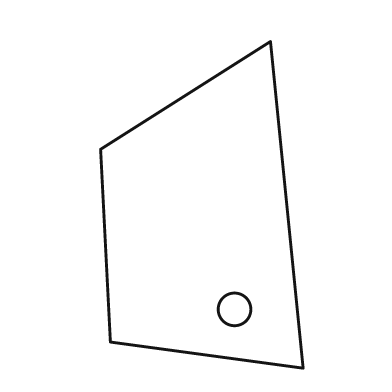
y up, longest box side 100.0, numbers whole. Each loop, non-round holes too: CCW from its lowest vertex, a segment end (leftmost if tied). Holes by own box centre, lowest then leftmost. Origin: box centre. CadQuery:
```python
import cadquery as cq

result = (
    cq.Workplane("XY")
    .moveTo(31.0, -50.0)
    .lineTo(21.0, 50.0)
    .lineTo(-31.0, 17.0)
    .lineTo(-28.0, -42.0)
    .close()
    .moveTo(10.0, -32.0)
    .circle(5.0)
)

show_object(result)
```